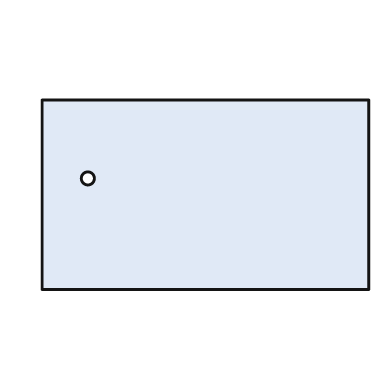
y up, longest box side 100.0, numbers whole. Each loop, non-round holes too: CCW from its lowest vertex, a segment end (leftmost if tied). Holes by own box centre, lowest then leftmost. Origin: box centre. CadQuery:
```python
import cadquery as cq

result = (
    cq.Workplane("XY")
    .moveTo(-50.0, -29.0)
    .lineTo(50.0, -29.0)
    .lineTo(50.0, 29.0)
    .lineTo(-50.0, 29.0)
    .close()
    .moveTo(-36.0, 5.0)
    .circle(2.0)
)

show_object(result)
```